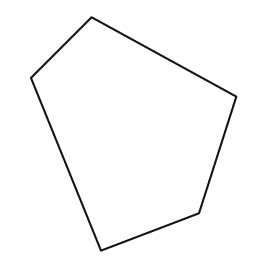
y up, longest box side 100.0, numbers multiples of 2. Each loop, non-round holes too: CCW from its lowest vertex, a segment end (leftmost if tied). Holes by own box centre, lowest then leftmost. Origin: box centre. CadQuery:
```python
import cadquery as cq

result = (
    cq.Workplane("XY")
    .moveTo(-14.0, -50.0)
    .lineTo(28.0, -34.0)
    .lineTo(44.0, 16.0)
    .lineTo(-18.0, 50.0)
    .lineTo(-44.0, 24.0)
    .close()
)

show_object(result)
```